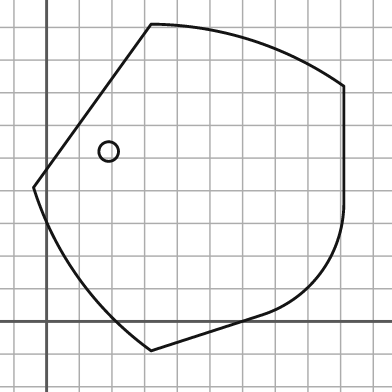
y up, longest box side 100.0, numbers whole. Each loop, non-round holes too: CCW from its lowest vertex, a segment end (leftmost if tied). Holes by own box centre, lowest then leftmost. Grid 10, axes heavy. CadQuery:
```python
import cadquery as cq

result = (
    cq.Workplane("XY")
    .moveTo(32.0, -9.0)
    .lineTo(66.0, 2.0)
    .threePointArc((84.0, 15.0), (91.0, 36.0))
    .lineTo(91.0, 72.0)
    .threePointArc((63.0, 86.0), (32.0, 91.0))
    .lineTo(-4.0, 41.0)
    .threePointArc((10.0, 13.0), (32.0, -9.0))
    .close()
    .moveTo(19.0, 52.0)
    .circle(3.0)
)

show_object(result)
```